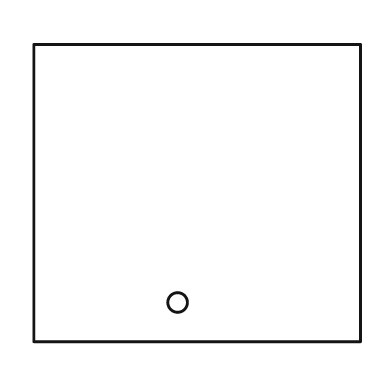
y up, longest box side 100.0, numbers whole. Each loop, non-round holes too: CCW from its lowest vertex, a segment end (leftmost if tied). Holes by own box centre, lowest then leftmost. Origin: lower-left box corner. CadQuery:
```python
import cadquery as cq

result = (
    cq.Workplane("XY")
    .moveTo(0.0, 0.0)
    .lineTo(100.0, 0.0)
    .lineTo(100.0, 91.0)
    .lineTo(0.0, 91.0)
    .close()
    .moveTo(44.0, 12.0)
    .circle(3.0)
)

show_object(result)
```